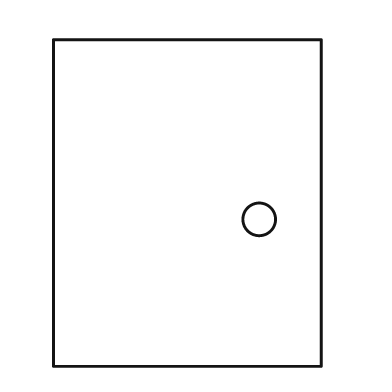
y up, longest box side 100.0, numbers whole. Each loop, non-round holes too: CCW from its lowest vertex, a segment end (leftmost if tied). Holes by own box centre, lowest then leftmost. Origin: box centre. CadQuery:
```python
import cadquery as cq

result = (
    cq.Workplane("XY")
    .moveTo(-41.0, -50.0)
    .lineTo(41.0, -50.0)
    .lineTo(41.0, 50.0)
    .lineTo(-41.0, 50.0)
    .close()
    .moveTo(22.0, -5.0)
    .circle(5.0)
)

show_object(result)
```